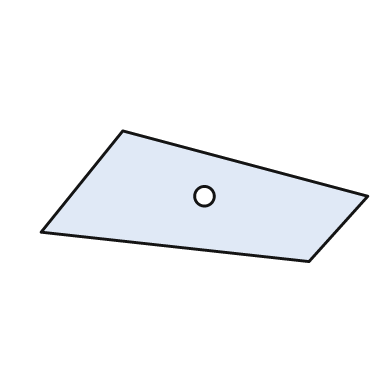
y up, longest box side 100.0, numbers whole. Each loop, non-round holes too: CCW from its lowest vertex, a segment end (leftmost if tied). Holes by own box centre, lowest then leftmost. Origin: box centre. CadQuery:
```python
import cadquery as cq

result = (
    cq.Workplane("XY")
    .moveTo(32.0, -20.0)
    .lineTo(50.0, 0.0)
    .lineTo(-25.0, 20.0)
    .lineTo(-50.0, -11.0)
    .close()
    .moveTo(0.0, 0.0)
    .circle(3.0)
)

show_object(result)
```